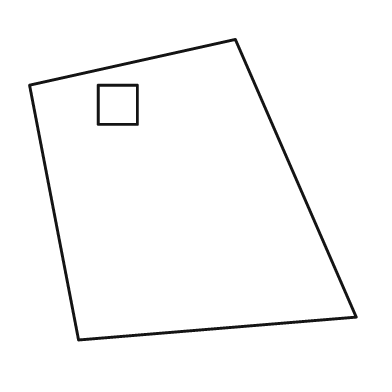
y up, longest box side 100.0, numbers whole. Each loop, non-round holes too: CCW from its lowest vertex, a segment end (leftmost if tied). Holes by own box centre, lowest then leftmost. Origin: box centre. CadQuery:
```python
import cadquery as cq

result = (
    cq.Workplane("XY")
    .moveTo(-35.0, -46.0)
    .lineTo(50.0, -39.0)
    .lineTo(13.0, 46.0)
    .lineTo(-50.0, 32.0)
    .close()
    .moveTo(-29.0, 20.0)
    .lineTo(-17.0, 20.0)
    .lineTo(-17.0, 32.0)
    .lineTo(-29.0, 32.0)
    .close()
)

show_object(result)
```